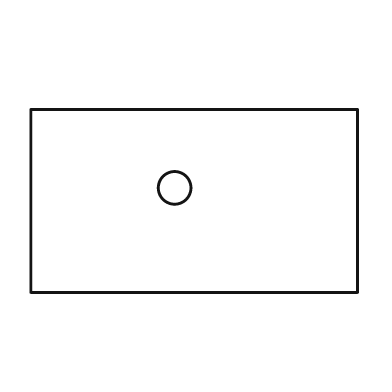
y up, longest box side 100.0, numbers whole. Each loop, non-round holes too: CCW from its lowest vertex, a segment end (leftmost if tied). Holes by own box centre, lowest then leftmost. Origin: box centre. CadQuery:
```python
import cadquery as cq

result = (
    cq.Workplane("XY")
    .moveTo(-50.0, -28.0)
    .lineTo(50.0, -28.0)
    .lineTo(50.0, 28.0)
    .lineTo(-50.0, 28.0)
    .close()
    .moveTo(-6.0, 4.0)
    .circle(5.0)
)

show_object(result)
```